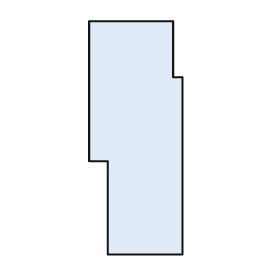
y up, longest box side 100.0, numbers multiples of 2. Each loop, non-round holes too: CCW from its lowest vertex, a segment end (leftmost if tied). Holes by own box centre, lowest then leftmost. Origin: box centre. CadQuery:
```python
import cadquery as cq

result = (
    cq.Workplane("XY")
    .moveTo(-12.0, -50.0)
    .lineTo(20.0, -50.0)
    .lineTo(20.0, 26.0)
    .lineTo(16.0, 26.0)
    .lineTo(16.0, 50.0)
    .lineTo(-20.0, 50.0)
    .lineTo(-20.0, -10.0)
    .lineTo(-12.0, -10.0)
    .close()
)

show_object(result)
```